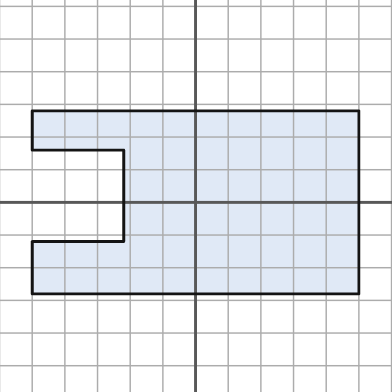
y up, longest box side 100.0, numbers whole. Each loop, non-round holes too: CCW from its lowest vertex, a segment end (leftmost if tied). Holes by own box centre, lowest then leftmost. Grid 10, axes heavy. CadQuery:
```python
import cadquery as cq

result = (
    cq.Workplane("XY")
    .moveTo(-50.0, -28.0)
    .lineTo(50.0, -28.0)
    .lineTo(50.0, 28.0)
    .lineTo(-50.0, 28.0)
    .lineTo(-50.0, 16.0)
    .lineTo(-22.0, 16.0)
    .lineTo(-22.0, -12.0)
    .lineTo(-50.0, -12.0)
    .close()
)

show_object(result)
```